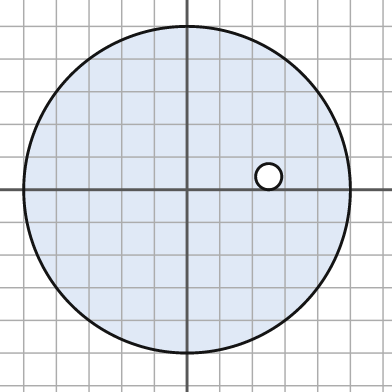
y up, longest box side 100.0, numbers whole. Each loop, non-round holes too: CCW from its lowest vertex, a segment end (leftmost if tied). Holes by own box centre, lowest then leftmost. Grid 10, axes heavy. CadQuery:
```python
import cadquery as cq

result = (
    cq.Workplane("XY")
    .moveTo(0.0, 0.0)
    .circle(50.0)
    .moveTo(25.0, 4.0)
    .circle(4.0)
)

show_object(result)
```